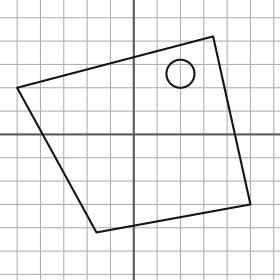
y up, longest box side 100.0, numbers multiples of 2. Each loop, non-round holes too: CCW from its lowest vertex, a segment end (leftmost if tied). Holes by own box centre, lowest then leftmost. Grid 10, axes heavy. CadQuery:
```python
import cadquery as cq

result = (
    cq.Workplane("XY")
    .moveTo(-16.0, -42.0)
    .lineTo(50.0, -30.0)
    .lineTo(34.0, 42.0)
    .lineTo(-50.0, 20.0)
    .close()
    .moveTo(20.0, 26.0)
    .circle(6.0)
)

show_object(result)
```